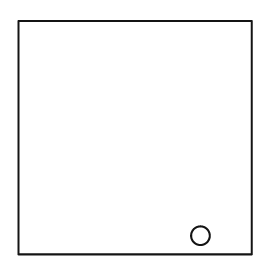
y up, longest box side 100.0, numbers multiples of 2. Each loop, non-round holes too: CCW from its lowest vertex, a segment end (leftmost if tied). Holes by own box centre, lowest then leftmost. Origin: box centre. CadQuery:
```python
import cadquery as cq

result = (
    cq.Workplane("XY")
    .moveTo(-50.0, -50.0)
    .lineTo(50.0, -50.0)
    .lineTo(50.0, 50.0)
    .lineTo(-50.0, 50.0)
    .close()
    .moveTo(28.0, -42.0)
    .circle(4.0)
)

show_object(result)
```